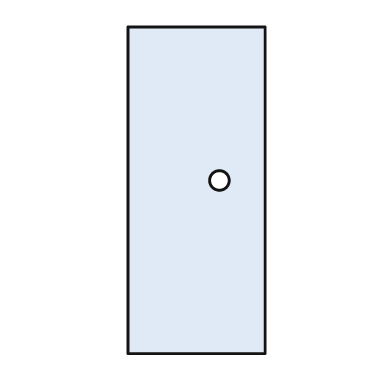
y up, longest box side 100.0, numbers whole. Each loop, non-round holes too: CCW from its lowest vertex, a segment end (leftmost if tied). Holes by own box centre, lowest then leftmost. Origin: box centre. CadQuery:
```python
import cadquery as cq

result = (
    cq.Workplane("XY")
    .moveTo(-21.0, -50.0)
    .lineTo(21.0, -50.0)
    .lineTo(21.0, 50.0)
    .lineTo(-21.0, 50.0)
    .close()
    .moveTo(7.0, 3.0)
    .circle(3.0)
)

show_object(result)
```